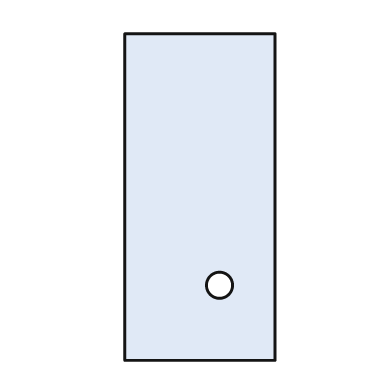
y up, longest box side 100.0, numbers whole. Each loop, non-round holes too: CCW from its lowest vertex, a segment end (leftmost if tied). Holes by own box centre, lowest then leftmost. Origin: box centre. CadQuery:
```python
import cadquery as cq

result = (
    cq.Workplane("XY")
    .moveTo(-23.0, -50.0)
    .lineTo(23.0, -50.0)
    .lineTo(23.0, 50.0)
    .lineTo(-23.0, 50.0)
    .close()
    .moveTo(6.0, -27.0)
    .circle(4.0)
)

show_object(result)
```